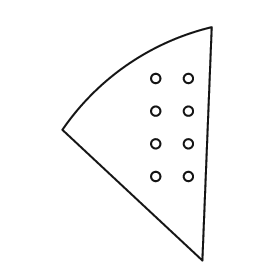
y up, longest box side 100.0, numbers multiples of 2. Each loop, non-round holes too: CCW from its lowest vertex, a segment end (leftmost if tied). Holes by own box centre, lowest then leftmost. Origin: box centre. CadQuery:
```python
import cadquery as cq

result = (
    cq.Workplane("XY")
    .moveTo(28.0, -50.0)
    .lineTo(32.0, 50.0)
    .threePointArc((-4.0, 34.0), (-32.0, 6.0))
    .close()
    .moveTo(8.0, -14.0)
    .circle(2.0)
    .moveTo(22.0, -14.0)
    .circle(2.0)
    .moveTo(8.0, 0.0)
    .circle(2.0)
    .moveTo(22.0, 0.0)
    .circle(2.0)
    .moveTo(8.0, 14.0)
    .circle(2.0)
    .moveTo(22.0, 14.0)
    .circle(2.0)
    .moveTo(8.0, 28.0)
    .circle(2.0)
    .moveTo(22.0, 28.0)
    .circle(2.0)
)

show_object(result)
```